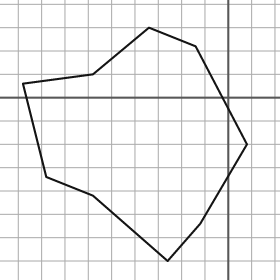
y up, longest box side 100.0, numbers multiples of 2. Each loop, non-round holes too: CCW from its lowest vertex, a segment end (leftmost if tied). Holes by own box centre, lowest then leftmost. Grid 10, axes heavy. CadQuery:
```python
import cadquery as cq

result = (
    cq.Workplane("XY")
    .moveTo(-26.0, -70.0)
    .lineTo(-12.0, -54.0)
    .lineTo(8.0, -20.0)
    .lineTo(-14.0, 22.0)
    .lineTo(-34.0, 30.0)
    .lineTo(-58.0, 10.0)
    .lineTo(-88.0, 6.0)
    .lineTo(-78.0, -34.0)
    .lineTo(-58.0, -42.0)
    .close()
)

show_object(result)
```